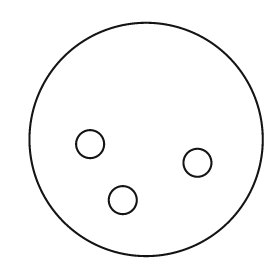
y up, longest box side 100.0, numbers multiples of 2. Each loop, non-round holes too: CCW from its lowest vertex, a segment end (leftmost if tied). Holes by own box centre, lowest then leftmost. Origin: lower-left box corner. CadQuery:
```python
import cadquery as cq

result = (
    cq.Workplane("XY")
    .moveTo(50.0, 50.0)
    .circle(50.0)
    .moveTo(40.0, 24.0)
    .circle(6.0)
    .moveTo(72.0, 40.0)
    .circle(6.0)
    .moveTo(26.0, 48.0)
    .circle(6.0)
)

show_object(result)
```